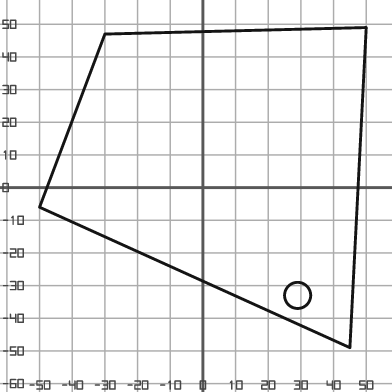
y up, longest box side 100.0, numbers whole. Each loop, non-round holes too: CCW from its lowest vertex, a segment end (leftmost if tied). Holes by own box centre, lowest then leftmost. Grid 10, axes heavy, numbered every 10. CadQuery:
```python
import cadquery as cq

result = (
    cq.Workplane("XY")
    .moveTo(45.0, -49.0)
    .lineTo(50.0, 49.0)
    .lineTo(-30.0, 47.0)
    .lineTo(-50.0, -6.0)
    .close()
    .moveTo(29.0, -33.0)
    .circle(4.0)
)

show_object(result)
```